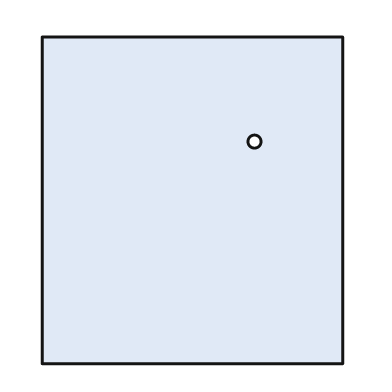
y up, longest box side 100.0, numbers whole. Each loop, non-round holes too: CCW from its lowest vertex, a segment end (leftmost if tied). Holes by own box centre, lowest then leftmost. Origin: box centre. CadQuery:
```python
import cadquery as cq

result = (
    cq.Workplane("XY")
    .moveTo(-46.0, -50.0)
    .lineTo(46.0, -50.0)
    .lineTo(46.0, 50.0)
    .lineTo(-46.0, 50.0)
    .close()
    .moveTo(19.0, 18.0)
    .circle(2.0)
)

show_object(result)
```